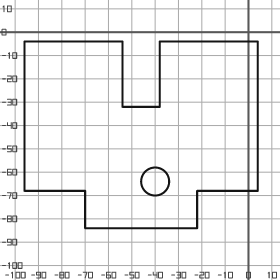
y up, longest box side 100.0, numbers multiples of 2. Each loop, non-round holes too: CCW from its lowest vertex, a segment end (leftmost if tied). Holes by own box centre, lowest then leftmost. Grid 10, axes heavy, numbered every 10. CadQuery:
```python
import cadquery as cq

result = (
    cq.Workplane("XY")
    .moveTo(-70.0, -84.0)
    .lineTo(-22.0, -84.0)
    .lineTo(-22.0, -68.0)
    .lineTo(4.0, -68.0)
    .lineTo(4.0, -4.0)
    .lineTo(-38.0, -4.0)
    .lineTo(-38.0, -32.0)
    .lineTo(-54.0, -32.0)
    .lineTo(-54.0, -4.0)
    .lineTo(-96.0, -4.0)
    .lineTo(-96.0, -68.0)
    .lineTo(-70.0, -68.0)
    .close()
    .moveTo(-40.0, -64.0)
    .circle(6.0)
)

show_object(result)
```